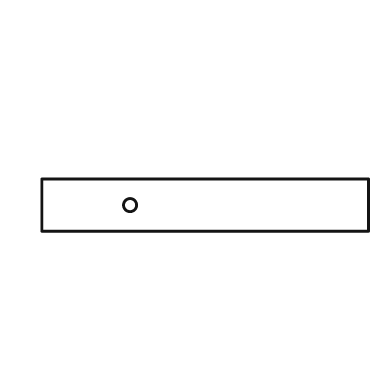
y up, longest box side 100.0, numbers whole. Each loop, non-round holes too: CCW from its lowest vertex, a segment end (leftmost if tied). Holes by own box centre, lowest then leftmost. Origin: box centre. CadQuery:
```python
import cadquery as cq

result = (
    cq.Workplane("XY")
    .moveTo(-50.0, -8.0)
    .lineTo(50.0, -8.0)
    .lineTo(50.0, 8.0)
    .lineTo(-50.0, 8.0)
    .close()
    .moveTo(-23.0, 0.0)
    .circle(2.0)
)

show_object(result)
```